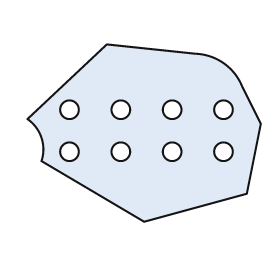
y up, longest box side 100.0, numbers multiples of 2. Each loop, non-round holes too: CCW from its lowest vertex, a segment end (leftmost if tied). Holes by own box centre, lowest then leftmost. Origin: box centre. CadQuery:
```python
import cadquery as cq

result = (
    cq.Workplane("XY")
    .moveTo(0.0, -38.0)
    .lineTo(44.0, -26.0)
    .lineTo(50.0, 4.0)
    .lineTo(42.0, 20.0)
    .threePointArc((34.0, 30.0), (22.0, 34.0))
    .lineTo(-16.0, 38.0)
    .lineTo(-50.0, 6.0)
    .threePointArc((-44.0, -2.0), (-44.0, -12.0))
    .close()
    .moveTo(-32.0, -8.0)
    .circle(4.0)
    .moveTo(-10.0, -8.0)
    .circle(4.0)
    .moveTo(12.0, -8.0)
    .circle(4.0)
    .moveTo(34.0, -8.0)
    .circle(4.0)
    .moveTo(-32.0, 10.0)
    .circle(4.0)
    .moveTo(-10.0, 10.0)
    .circle(4.0)
    .moveTo(12.0, 10.0)
    .circle(4.0)
    .moveTo(34.0, 10.0)
    .circle(4.0)
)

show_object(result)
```